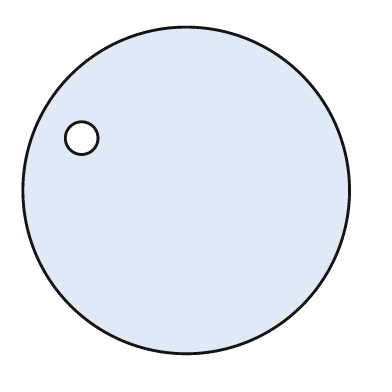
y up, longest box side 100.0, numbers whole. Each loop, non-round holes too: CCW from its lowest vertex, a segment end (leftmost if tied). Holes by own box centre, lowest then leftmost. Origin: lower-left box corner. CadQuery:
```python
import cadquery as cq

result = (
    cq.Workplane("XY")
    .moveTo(50.0, 50.0)
    .circle(50.0)
    .moveTo(18.0, 66.0)
    .circle(5.0)
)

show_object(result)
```